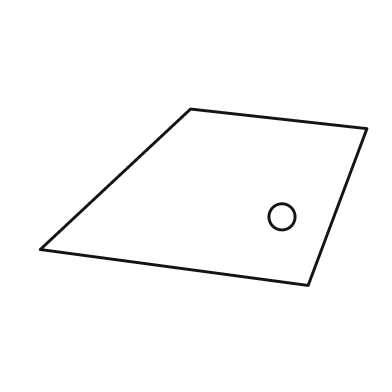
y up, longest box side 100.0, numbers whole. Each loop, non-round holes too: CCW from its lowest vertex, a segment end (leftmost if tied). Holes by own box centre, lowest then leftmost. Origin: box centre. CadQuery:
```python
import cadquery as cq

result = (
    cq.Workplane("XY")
    .moveTo(32.0, -27.0)
    .lineTo(50.0, 21.0)
    .lineTo(-4.0, 27.0)
    .lineTo(-50.0, -16.0)
    .close()
    .moveTo(24.0, -6.0)
    .circle(4.0)
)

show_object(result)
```